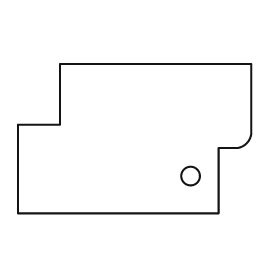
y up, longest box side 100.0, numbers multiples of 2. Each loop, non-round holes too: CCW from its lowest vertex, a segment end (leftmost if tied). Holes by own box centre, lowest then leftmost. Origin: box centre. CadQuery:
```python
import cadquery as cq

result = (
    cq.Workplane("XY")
    .moveTo(-50.0, -32.0)
    .lineTo(36.0, -32.0)
    .lineTo(36.0, -4.0)
    .lineTo(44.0, -4.0)
    .threePointArc((48.0, -2.0), (50.0, 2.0))
    .lineTo(50.0, 32.0)
    .lineTo(-32.0, 32.0)
    .lineTo(-32.0, 6.0)
    .lineTo(-50.0, 6.0)
    .close()
    .moveTo(24.0, -16.0)
    .circle(4.0)
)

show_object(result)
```